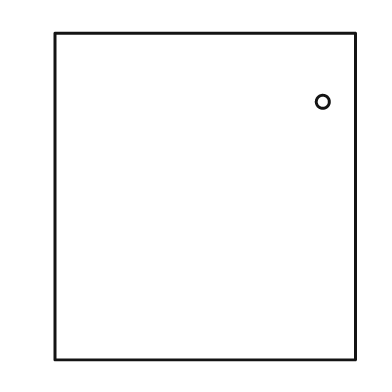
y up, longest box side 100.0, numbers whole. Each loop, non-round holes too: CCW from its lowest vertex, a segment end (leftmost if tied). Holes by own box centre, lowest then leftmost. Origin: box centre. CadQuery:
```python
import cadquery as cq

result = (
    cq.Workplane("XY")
    .moveTo(-46.0, -50.0)
    .lineTo(46.0, -50.0)
    .lineTo(46.0, 50.0)
    .lineTo(-46.0, 50.0)
    .close()
    .moveTo(36.0, 29.0)
    .circle(2.0)
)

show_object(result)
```